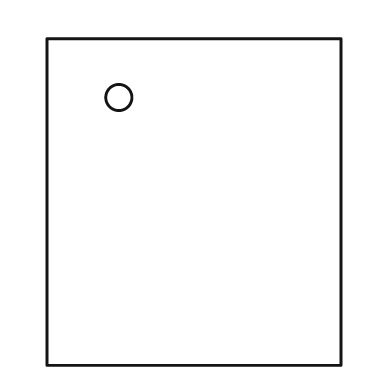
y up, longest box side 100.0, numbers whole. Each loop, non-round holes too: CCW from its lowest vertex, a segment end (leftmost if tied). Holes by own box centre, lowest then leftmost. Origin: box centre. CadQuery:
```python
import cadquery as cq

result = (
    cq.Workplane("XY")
    .moveTo(-45.0, -50.0)
    .lineTo(45.0, -50.0)
    .lineTo(45.0, 50.0)
    .lineTo(-45.0, 50.0)
    .close()
    .moveTo(-23.0, 32.0)
    .circle(4.0)
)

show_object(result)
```